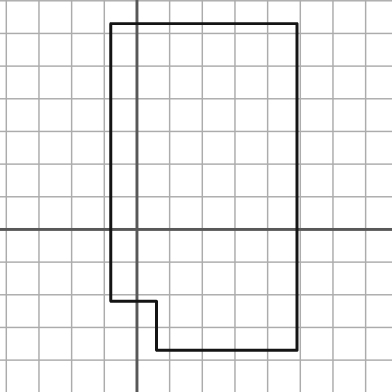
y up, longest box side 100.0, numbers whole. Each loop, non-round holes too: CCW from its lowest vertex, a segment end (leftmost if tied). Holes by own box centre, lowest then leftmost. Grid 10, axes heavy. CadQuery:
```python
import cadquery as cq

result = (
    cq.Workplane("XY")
    .moveTo(6.0, -37.0)
    .lineTo(49.0, -37.0)
    .lineTo(49.0, 63.0)
    .lineTo(-8.0, 63.0)
    .lineTo(-8.0, -22.0)
    .lineTo(6.0, -22.0)
    .close()
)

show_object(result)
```